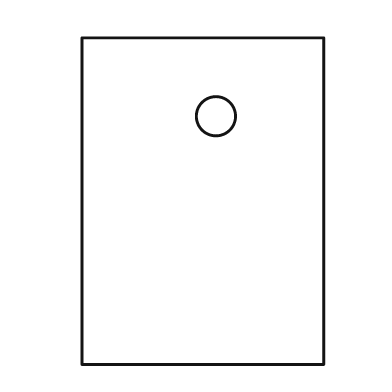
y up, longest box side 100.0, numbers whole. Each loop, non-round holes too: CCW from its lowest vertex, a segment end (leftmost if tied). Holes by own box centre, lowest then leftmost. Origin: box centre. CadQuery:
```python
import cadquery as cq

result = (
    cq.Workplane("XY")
    .moveTo(-37.0, -50.0)
    .lineTo(37.0, -50.0)
    .lineTo(37.0, 50.0)
    .lineTo(-37.0, 50.0)
    .close()
    .moveTo(4.0, 26.0)
    .circle(6.0)
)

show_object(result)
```